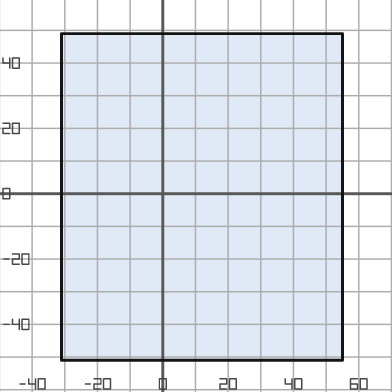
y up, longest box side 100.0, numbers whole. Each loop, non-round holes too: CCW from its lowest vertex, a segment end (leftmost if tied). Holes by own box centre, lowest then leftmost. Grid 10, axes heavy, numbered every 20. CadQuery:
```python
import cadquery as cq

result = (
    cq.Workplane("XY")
    .moveTo(-31.0, -51.0)
    .lineTo(55.0, -51.0)
    .lineTo(55.0, 49.0)
    .lineTo(-31.0, 49.0)
    .close()
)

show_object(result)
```